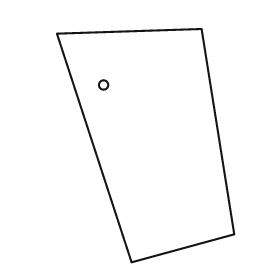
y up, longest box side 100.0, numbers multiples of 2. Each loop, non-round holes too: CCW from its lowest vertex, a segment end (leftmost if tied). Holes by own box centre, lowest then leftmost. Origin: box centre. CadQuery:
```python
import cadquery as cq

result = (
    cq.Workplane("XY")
    .moveTo(-6.0, -50.0)
    .lineTo(38.0, -38.0)
    .lineTo(24.0, 50.0)
    .lineTo(-38.0, 48.0)
    .close()
    .moveTo(-18.0, 26.0)
    .circle(2.0)
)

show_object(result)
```